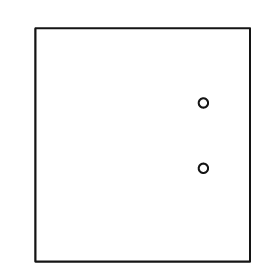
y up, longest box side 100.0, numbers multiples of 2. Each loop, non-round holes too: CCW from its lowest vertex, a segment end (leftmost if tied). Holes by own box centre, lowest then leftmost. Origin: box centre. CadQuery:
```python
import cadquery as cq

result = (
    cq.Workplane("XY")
    .moveTo(-46.0, -50.0)
    .lineTo(46.0, -50.0)
    .lineTo(46.0, 50.0)
    .lineTo(-46.0, 50.0)
    .close()
    .moveTo(26.0, -10.0)
    .circle(2.0)
    .moveTo(26.0, 18.0)
    .circle(2.0)
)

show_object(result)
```